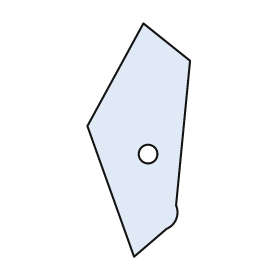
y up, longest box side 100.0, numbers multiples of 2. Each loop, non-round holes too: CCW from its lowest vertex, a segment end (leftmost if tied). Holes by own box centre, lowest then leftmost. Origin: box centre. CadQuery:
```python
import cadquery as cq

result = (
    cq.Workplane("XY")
    .moveTo(-2.0, -50.0)
    .lineTo(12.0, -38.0)
    .threePointArc((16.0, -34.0), (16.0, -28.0))
    .lineTo(22.0, 34.0)
    .lineTo(2.0, 50.0)
    .lineTo(-22.0, 6.0)
    .close()
    .moveTo(4.0, -6.0)
    .circle(4.0)
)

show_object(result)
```